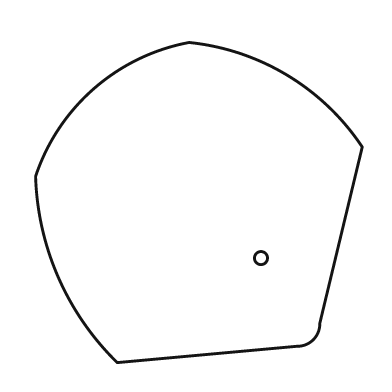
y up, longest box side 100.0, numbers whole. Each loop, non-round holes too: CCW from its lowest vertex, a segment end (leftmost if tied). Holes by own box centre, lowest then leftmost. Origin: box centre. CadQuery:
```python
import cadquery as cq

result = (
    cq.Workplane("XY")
    .moveTo(-25.0, -49.0)
    .lineTo(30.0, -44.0)
    .threePointArc((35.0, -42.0), (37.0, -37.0))
    .lineTo(50.0, 17.0)
    .threePointArc((27.0, 39.0), (-3.0, 49.0))
    .threePointArc((-32.0, 35.0), (-50.0, 8.0))
    .threePointArc((-43.0, -23.0), (-25.0, -49.0))
    .close()
    .moveTo(19.0, -17.0)
    .circle(2.0)
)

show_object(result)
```